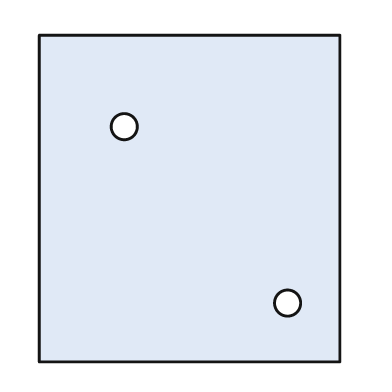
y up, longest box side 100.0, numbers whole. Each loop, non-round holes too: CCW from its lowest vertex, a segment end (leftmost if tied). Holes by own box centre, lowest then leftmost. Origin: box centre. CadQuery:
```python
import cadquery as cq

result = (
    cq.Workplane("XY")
    .moveTo(-46.0, -50.0)
    .lineTo(46.0, -50.0)
    .lineTo(46.0, 50.0)
    .lineTo(-46.0, 50.0)
    .close()
    .moveTo(30.0, -32.0)
    .circle(4.0)
    .moveTo(-20.0, 22.0)
    .circle(4.0)
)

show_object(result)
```